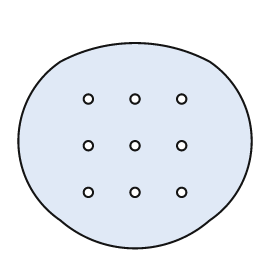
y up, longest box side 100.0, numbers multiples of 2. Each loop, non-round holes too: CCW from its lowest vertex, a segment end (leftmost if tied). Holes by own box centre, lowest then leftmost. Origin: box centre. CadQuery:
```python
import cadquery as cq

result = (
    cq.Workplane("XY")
    .moveTo(-32.0, -32.0)
    .threePointArc((0.0, -44.0), (32.0, -32.0))
    .threePointArc((50.0, 2.0), (32.0, 36.0))
    .threePointArc((0.0, 44.0), (-32.0, 36.0))
    .threePointArc((-50.0, 2.0), (-32.0, -32.0))
    .close()
    .moveTo(-20.0, -20.0)
    .circle(2.0)
    .moveTo(0.0, -20.0)
    .circle(2.0)
    .moveTo(20.0, -20.0)
    .circle(2.0)
    .moveTo(-20.0, 0.0)
    .circle(2.0)
    .moveTo(0.0, 0.0)
    .circle(2.0)
    .moveTo(20.0, 0.0)
    .circle(2.0)
    .moveTo(-20.0, 20.0)
    .circle(2.0)
    .moveTo(0.0, 20.0)
    .circle(2.0)
    .moveTo(20.0, 20.0)
    .circle(2.0)
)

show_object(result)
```